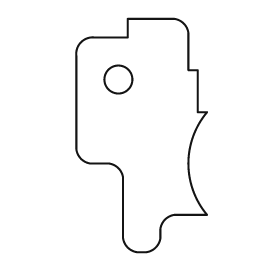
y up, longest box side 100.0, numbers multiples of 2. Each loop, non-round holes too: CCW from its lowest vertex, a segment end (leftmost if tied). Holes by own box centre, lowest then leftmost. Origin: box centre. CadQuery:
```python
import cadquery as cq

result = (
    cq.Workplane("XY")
    .moveTo(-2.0, -50.0)
    .lineTo(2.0, -50.0)
    .threePointArc((6.0, -48.0), (8.0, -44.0))
    .lineTo(8.0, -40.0)
    .threePointArc((10.0, -36.0), (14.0, -34.0))
    .lineTo(28.0, -34.0)
    .threePointArc((20.0, -12.0), (28.0, 10.0))
    .lineTo(24.0, 10.0)
    .lineTo(24.0, 28.0)
    .lineTo(20.0, 28.0)
    .lineTo(20.0, 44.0)
    .threePointArc((18.0, 48.0), (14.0, 50.0))
    .lineTo(-6.0, 50.0)
    .lineTo(-6.0, 42.0)
    .lineTo(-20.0, 42.0)
    .threePointArc((-26.0, 40.0), (-28.0, 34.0))
    .lineTo(-28.0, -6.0)
    .threePointArc((-26.0, -10.0), (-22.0, -12.0))
    .lineTo(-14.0, -12.0)
    .threePointArc((-10.0, -14.0), (-8.0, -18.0))
    .lineTo(-8.0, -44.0)
    .threePointArc((-6.0, -48.0), (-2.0, -50.0))
    .close()
    .moveTo(-10.0, 24.0)
    .circle(6.0)
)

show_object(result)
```